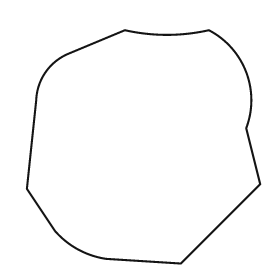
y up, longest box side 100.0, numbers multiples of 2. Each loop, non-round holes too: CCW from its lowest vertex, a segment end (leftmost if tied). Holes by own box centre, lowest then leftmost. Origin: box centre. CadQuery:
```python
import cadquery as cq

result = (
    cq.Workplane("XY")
    .moveTo(16.0, -50.0)
    .lineTo(50.0, -16.0)
    .lineTo(44.0, 8.0)
    .threePointArc((44.0, 32.0), (28.0, 50.0))
    .threePointArc((10.0, 48.0), (-8.0, 50.0))
    .lineTo(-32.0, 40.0)
    .threePointArc((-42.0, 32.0), (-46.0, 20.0))
    .lineTo(-50.0, -18.0)
    .lineTo(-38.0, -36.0)
    .threePointArc((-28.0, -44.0), (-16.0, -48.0))
    .close()
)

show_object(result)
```